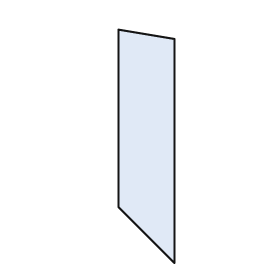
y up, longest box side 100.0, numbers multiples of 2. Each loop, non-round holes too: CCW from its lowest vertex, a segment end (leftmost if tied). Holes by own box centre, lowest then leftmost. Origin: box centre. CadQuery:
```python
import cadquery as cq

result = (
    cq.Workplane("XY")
    .moveTo(12.0, -50.0)
    .lineTo(12.0, 46.0)
    .lineTo(-12.0, 50.0)
    .lineTo(-12.0, -26.0)
    .close()
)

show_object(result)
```